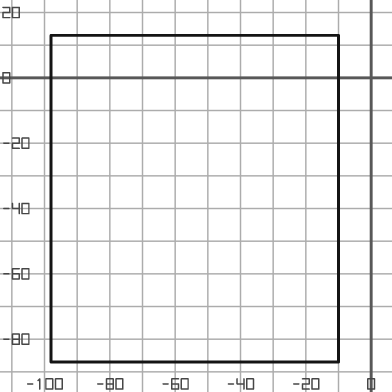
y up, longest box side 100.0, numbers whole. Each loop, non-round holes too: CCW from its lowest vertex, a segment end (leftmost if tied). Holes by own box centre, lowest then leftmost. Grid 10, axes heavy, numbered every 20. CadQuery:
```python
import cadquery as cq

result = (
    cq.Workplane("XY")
    .moveTo(-98.0, -87.0)
    .lineTo(-10.0, -87.0)
    .lineTo(-10.0, 13.0)
    .lineTo(-98.0, 13.0)
    .close()
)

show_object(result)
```